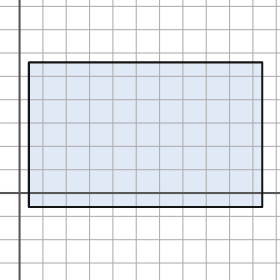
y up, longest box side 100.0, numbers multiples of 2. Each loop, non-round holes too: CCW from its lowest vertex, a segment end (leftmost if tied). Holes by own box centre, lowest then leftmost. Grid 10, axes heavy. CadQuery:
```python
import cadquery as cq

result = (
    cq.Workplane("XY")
    .moveTo(4.0, -6.0)
    .lineTo(104.0, -6.0)
    .lineTo(104.0, 56.0)
    .lineTo(4.0, 56.0)
    .close()
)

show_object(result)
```